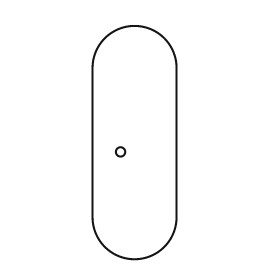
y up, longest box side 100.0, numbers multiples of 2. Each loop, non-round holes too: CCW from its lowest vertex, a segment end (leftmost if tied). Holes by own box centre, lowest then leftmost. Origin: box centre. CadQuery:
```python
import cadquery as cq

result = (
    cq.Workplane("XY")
    .moveTo(-18.0, -32.0)
    .threePointArc((0.0, -50.0), (18.0, -32.0))
    .lineTo(18.0, 32.0)
    .threePointArc((0.0, 50.0), (-18.0, 32.0))
    .close()
    .moveTo(-6.0, -4.0)
    .circle(2.0)
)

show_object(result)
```